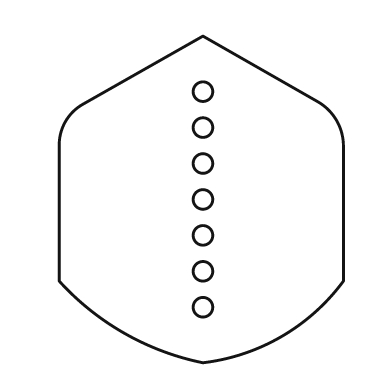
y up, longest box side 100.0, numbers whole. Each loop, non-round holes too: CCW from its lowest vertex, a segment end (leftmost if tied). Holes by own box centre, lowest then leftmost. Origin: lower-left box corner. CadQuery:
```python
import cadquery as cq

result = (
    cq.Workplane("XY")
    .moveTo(44.0, 0.0)
    .threePointArc((68.0, 8.0), (87.0, 25.0))
    .lineTo(87.0, 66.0)
    .threePointArc((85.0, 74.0), (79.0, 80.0))
    .lineTo(44.0, 100.0)
    .lineTo(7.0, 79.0)
    .threePointArc((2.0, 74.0), (0.0, 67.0))
    .lineTo(0.0, 25.0)
    .threePointArc((20.0, 9.0), (44.0, 0.0))
    .close()
    .moveTo(44.0, 17.0)
    .circle(3.0)
    .moveTo(44.0, 28.0)
    .circle(3.0)
    .moveTo(44.0, 39.0)
    .circle(3.0)
    .moveTo(44.0, 50.0)
    .circle(3.0)
    .moveTo(44.0, 61.0)
    .circle(3.0)
    .moveTo(44.0, 72.0)
    .circle(3.0)
    .moveTo(44.0, 83.0)
    .circle(3.0)
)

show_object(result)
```